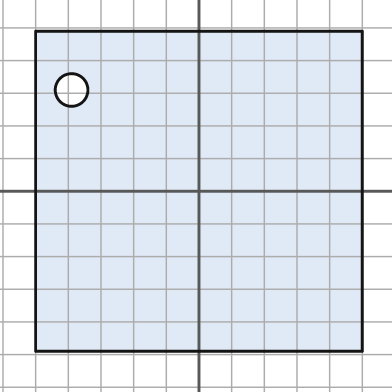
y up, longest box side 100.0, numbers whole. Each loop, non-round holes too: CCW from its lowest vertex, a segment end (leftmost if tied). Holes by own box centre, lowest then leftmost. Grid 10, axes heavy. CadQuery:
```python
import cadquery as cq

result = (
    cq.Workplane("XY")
    .moveTo(-50.0, -49.0)
    .lineTo(50.0, -49.0)
    .lineTo(50.0, 49.0)
    .lineTo(-50.0, 49.0)
    .close()
    .moveTo(-39.0, 31.0)
    .circle(5.0)
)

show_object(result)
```